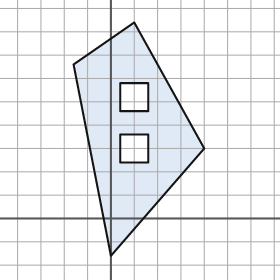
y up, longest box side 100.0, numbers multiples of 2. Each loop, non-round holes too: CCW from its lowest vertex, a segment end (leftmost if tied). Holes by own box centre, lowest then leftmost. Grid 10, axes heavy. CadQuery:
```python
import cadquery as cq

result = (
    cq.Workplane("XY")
    .moveTo(0.0, -16.0)
    .lineTo(40.0, 30.0)
    .lineTo(10.0, 84.0)
    .lineTo(-16.0, 66.0)
    .close()
    .moveTo(4.0, 24.0)
    .lineTo(16.0, 24.0)
    .lineTo(16.0, 36.0)
    .lineTo(4.0, 36.0)
    .close()
    .moveTo(4.0, 46.0)
    .lineTo(16.0, 46.0)
    .lineTo(16.0, 58.0)
    .lineTo(4.0, 58.0)
    .close()
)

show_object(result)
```